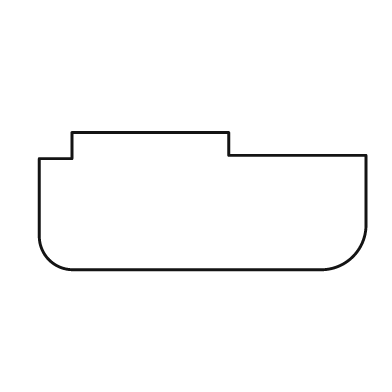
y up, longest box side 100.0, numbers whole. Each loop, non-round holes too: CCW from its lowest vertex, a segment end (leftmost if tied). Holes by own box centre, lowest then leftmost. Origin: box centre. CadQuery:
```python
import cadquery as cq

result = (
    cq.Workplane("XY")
    .moveTo(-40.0, -21.0)
    .lineTo(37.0, -21.0)
    .threePointArc((46.0, -17.0), (50.0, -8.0))
    .lineTo(50.0, 14.0)
    .lineTo(8.0, 14.0)
    .lineTo(8.0, 21.0)
    .lineTo(-40.0, 21.0)
    .lineTo(-40.0, 13.0)
    .lineTo(-50.0, 13.0)
    .lineTo(-50.0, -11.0)
    .threePointArc((-47.0, -18.0), (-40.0, -21.0))
    .close()
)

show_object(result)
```